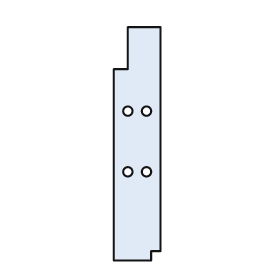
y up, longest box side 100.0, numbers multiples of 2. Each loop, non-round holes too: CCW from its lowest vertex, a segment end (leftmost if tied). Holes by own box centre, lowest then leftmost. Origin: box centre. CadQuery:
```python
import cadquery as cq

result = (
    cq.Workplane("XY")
    .moveTo(-10.0, -50.0)
    .lineTo(6.0, -50.0)
    .lineTo(6.0, -46.0)
    .lineTo(10.0, -46.0)
    .lineTo(10.0, 50.0)
    .lineTo(-4.0, 50.0)
    .lineTo(-4.0, 32.0)
    .lineTo(-10.0, 32.0)
    .close()
    .moveTo(-4.0, -12.0)
    .circle(2.0)
    .moveTo(4.0, -12.0)
    .circle(2.0)
    .moveTo(-4.0, 14.0)
    .circle(2.0)
    .moveTo(4.0, 14.0)
    .circle(2.0)
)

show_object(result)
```